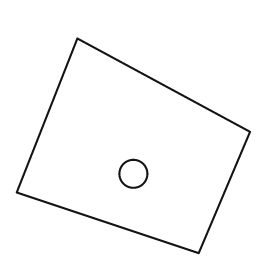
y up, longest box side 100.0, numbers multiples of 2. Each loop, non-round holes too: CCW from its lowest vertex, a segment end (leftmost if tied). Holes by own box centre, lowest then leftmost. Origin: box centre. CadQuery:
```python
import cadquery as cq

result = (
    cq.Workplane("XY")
    .moveTo(28.0, -46.0)
    .lineTo(50.0, 6.0)
    .lineTo(-24.0, 46.0)
    .lineTo(-50.0, -20.0)
    .close()
    .moveTo(0.0, -12.0)
    .circle(6.0)
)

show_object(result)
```